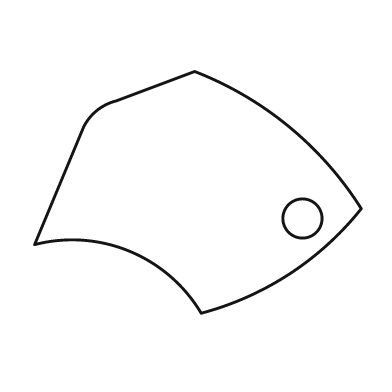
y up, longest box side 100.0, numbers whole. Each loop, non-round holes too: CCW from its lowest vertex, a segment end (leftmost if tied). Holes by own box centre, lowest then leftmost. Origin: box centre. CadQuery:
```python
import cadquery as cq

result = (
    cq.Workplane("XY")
    .moveTo(1.0, -37.0)
    .threePointArc((28.0, -25.0), (50.0, -5.0))
    .threePointArc((28.0, 20.0), (-1.0, 37.0))
    .lineTo(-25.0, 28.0)
    .threePointArc((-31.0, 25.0), (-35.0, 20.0))
    .lineTo(-50.0, -16.0)
    .threePointArc((-21.0, -18.0), (1.0, -37.0))
    .close()
    .moveTo(32.0, -8.0)
    .circle(6.0)
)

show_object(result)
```